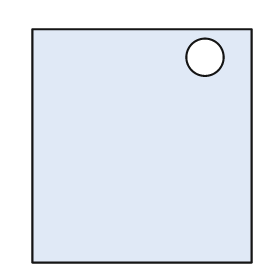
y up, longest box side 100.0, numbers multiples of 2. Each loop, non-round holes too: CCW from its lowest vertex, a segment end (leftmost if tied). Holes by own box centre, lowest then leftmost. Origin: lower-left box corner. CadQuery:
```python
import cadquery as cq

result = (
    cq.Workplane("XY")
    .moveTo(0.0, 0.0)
    .lineTo(94.0, 0.0)
    .lineTo(94.0, 100.0)
    .lineTo(0.0, 100.0)
    .close()
    .moveTo(74.0, 88.0)
    .circle(8.0)
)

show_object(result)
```